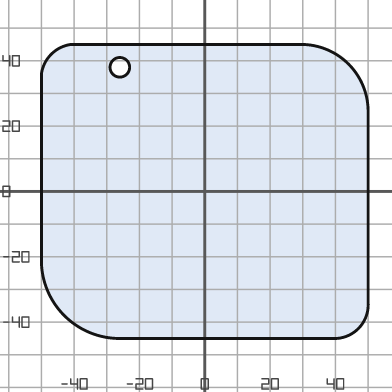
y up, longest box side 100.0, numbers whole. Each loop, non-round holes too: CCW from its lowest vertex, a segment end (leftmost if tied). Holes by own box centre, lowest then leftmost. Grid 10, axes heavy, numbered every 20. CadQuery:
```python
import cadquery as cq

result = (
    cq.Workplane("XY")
    .moveTo(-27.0, -45.0)
    .lineTo(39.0, -45.0)
    .threePointArc((47.0, -42.0), (50.0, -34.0))
    .lineTo(50.0, 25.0)
    .threePointArc((44.0, 39.0), (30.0, 45.0))
    .lineTo(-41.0, 45.0)
    .threePointArc((-47.0, 42.0), (-50.0, 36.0))
    .lineTo(-50.0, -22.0)
    .threePointArc((-43.0, -38.0), (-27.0, -45.0))
    .close()
    .moveTo(-26.0, 38.0)
    .circle(3.0)
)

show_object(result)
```